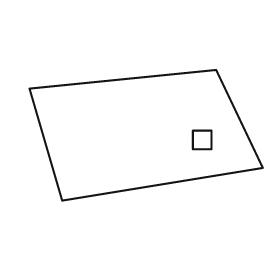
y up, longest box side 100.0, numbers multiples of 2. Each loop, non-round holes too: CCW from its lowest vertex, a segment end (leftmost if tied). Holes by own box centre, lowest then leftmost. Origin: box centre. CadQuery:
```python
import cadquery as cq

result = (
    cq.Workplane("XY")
    .moveTo(-36.0, -28.0)
    .lineTo(50.0, -14.0)
    .lineTo(30.0, 28.0)
    .lineTo(-50.0, 20.0)
    .close()
    .moveTo(20.0, -6.0)
    .lineTo(28.0, -6.0)
    .lineTo(28.0, 2.0)
    .lineTo(20.0, 2.0)
    .close()
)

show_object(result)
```